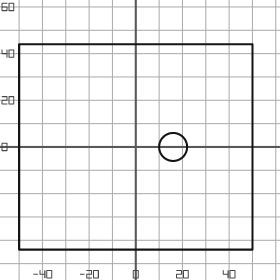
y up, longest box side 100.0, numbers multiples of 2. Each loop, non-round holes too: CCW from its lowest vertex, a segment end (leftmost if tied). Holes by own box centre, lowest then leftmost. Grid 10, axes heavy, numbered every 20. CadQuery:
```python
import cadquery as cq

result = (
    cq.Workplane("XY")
    .moveTo(-50.0, -44.0)
    .lineTo(50.0, -44.0)
    .lineTo(50.0, 44.0)
    .lineTo(-50.0, 44.0)
    .close()
    .moveTo(16.0, 0.0)
    .circle(6.0)
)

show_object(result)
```